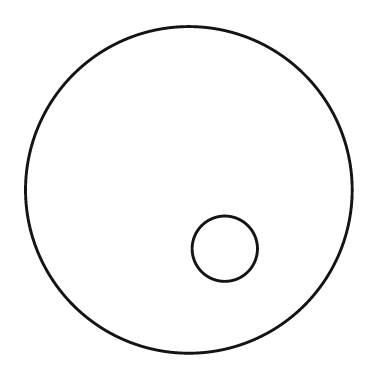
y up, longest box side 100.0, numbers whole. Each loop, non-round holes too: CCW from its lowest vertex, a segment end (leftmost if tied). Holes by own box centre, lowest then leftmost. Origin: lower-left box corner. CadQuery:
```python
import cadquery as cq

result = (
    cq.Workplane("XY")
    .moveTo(50.0, 50.0)
    .circle(50.0)
    .moveTo(61.0, 32.0)
    .circle(10.0)
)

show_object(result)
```